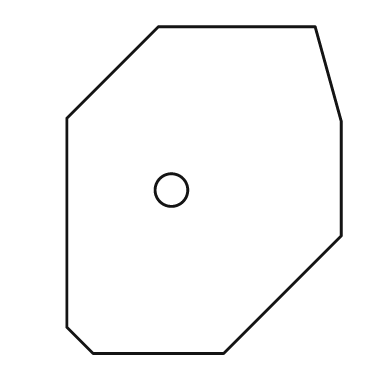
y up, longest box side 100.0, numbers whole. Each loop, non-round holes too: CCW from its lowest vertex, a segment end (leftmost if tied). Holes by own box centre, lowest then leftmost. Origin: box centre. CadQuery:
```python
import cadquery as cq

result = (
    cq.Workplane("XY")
    .moveTo(-34.0, -50.0)
    .lineTo(6.0, -50.0)
    .lineTo(42.0, -14.0)
    .lineTo(42.0, 21.0)
    .lineTo(34.0, 50.0)
    .lineTo(-14.0, 50.0)
    .lineTo(-42.0, 22.0)
    .lineTo(-42.0, -42.0)
    .close()
    .moveTo(-10.0, 0.0)
    .circle(5.0)
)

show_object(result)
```